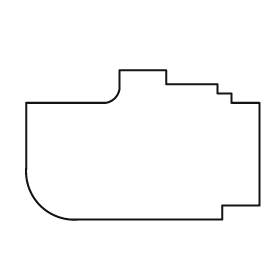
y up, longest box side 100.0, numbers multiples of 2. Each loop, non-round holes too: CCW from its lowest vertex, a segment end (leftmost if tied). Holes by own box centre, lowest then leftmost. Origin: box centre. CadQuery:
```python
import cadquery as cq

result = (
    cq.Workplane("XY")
    .moveTo(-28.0, -32.0)
    .lineTo(34.0, -32.0)
    .lineTo(34.0, -26.0)
    .lineTo(50.0, -26.0)
    .lineTo(50.0, 18.0)
    .lineTo(38.0, 18.0)
    .lineTo(38.0, 22.0)
    .lineTo(32.0, 22.0)
    .lineTo(32.0, 26.0)
    .lineTo(10.0, 26.0)
    .lineTo(10.0, 32.0)
    .lineTo(-10.0, 32.0)
    .lineTo(-10.0, 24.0)
    .threePointArc((-12.0, 20.0), (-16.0, 18.0))
    .lineTo(-50.0, 18.0)
    .lineTo(-50.0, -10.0)
    .threePointArc((-44.0, -26.0), (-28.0, -32.0))
    .close()
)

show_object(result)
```